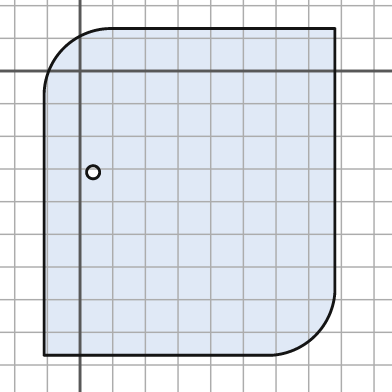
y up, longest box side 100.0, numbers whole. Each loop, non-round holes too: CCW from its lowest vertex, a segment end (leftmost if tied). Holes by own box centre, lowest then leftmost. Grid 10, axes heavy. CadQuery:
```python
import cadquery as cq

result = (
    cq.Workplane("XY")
    .moveTo(-11.0, -87.0)
    .lineTo(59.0, -87.0)
    .threePointArc((72.0, -81.0), (78.0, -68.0))
    .lineTo(78.0, 13.0)
    .lineTo(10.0, 13.0)
    .threePointArc((-5.0, 7.0), (-11.0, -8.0))
    .close()
    .moveTo(4.0, -31.0)
    .circle(2.0)
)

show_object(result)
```